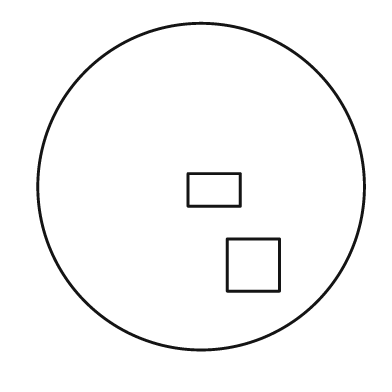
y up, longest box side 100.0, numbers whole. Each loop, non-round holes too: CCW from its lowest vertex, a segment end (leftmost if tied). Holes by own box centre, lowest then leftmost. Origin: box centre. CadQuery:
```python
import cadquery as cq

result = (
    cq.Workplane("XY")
    .moveTo(0.0, 0.0)
    .circle(50.0)
    .moveTo(8.0, -32.0)
    .lineTo(24.0, -32.0)
    .lineTo(24.0, -16.0)
    .lineTo(8.0, -16.0)
    .close()
    .moveTo(-4.0, -6.0)
    .lineTo(12.0, -6.0)
    .lineTo(12.0, 4.0)
    .lineTo(-4.0, 4.0)
    .close()
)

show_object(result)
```